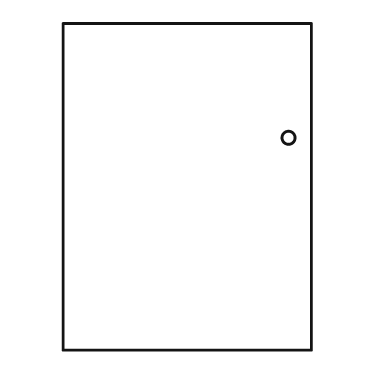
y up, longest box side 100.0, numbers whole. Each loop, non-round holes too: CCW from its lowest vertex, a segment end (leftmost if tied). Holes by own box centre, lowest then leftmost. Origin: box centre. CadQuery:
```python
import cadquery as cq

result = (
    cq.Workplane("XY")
    .moveTo(-38.0, -50.0)
    .lineTo(38.0, -50.0)
    .lineTo(38.0, 50.0)
    .lineTo(-38.0, 50.0)
    .close()
    .moveTo(31.0, 15.0)
    .circle(2.0)
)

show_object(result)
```